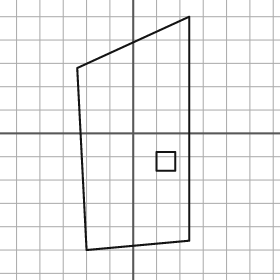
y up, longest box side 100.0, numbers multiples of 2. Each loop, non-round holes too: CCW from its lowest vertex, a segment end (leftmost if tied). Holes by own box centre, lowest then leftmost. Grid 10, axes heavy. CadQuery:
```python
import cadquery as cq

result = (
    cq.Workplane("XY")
    .moveTo(-20.0, -50.0)
    .lineTo(24.0, -46.0)
    .lineTo(24.0, 50.0)
    .lineTo(-24.0, 28.0)
    .close()
    .moveTo(10.0, -16.0)
    .lineTo(18.0, -16.0)
    .lineTo(18.0, -8.0)
    .lineTo(10.0, -8.0)
    .close()
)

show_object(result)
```